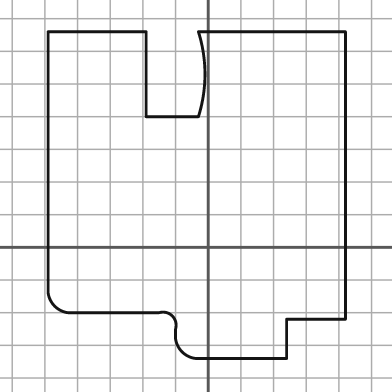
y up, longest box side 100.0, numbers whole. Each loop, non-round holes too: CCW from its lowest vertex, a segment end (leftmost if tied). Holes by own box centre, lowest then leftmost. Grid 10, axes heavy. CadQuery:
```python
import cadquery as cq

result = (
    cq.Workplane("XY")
    .moveTo(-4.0, -34.0)
    .lineTo(24.0, -34.0)
    .lineTo(24.0, -22.0)
    .lineTo(42.0, -22.0)
    .lineTo(42.0, 66.0)
    .lineTo(-3.0, 66.0)
    .threePointArc((-1.0, 53.0), (-3.0, 40.0))
    .lineTo(-19.0, 40.0)
    .lineTo(-19.0, 66.0)
    .lineTo(-49.0, 66.0)
    .lineTo(-49.0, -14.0)
    .threePointArc((-47.0, -18.0), (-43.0, -20.0))
    .lineTo(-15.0, -20.0)
    .threePointArc((-11.0, -21.0), (-10.0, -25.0))
    .lineTo(-10.0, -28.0)
    .threePointArc((-8.0, -32.0), (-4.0, -34.0))
    .close()
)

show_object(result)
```